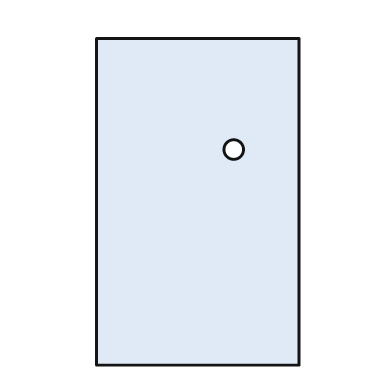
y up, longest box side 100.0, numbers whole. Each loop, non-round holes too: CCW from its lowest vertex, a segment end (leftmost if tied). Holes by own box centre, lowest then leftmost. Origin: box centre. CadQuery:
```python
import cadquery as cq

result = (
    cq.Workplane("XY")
    .moveTo(-31.0, -50.0)
    .lineTo(31.0, -50.0)
    .lineTo(31.0, 50.0)
    .lineTo(-31.0, 50.0)
    .close()
    .moveTo(11.0, 16.0)
    .circle(3.0)
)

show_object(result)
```